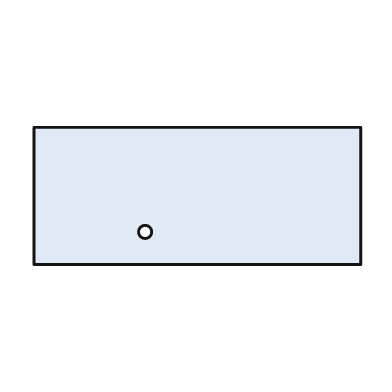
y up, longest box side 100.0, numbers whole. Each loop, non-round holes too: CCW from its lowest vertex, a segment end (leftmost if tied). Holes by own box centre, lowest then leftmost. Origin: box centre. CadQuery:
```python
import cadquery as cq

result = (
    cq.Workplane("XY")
    .moveTo(-50.0, -21.0)
    .lineTo(50.0, -21.0)
    .lineTo(50.0, 21.0)
    .lineTo(-50.0, 21.0)
    .close()
    .moveTo(-16.0, -11.0)
    .circle(2.0)
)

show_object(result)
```